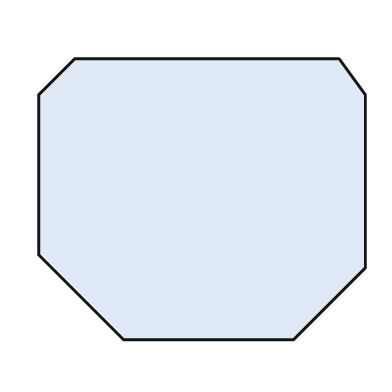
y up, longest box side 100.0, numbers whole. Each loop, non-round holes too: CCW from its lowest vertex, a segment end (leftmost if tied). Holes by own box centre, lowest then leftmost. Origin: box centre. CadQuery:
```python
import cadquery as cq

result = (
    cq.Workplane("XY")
    .moveTo(-24.0, -43.0)
    .lineTo(28.0, -43.0)
    .lineTo(50.0, -21.0)
    .lineTo(50.0, 32.0)
    .lineTo(42.0, 43.0)
    .lineTo(-39.0, 43.0)
    .lineTo(-50.0, 32.0)
    .lineTo(-50.0, -17.0)
    .close()
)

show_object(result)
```